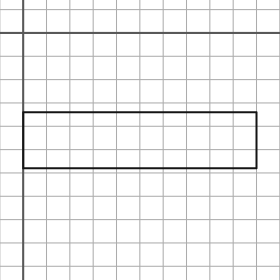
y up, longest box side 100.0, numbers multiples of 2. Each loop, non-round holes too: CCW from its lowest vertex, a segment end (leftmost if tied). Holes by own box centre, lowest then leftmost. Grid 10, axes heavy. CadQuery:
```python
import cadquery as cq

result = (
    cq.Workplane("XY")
    .moveTo(0.0, -58.0)
    .lineTo(100.0, -58.0)
    .lineTo(100.0, -34.0)
    .lineTo(0.0, -34.0)
    .close()
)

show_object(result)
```